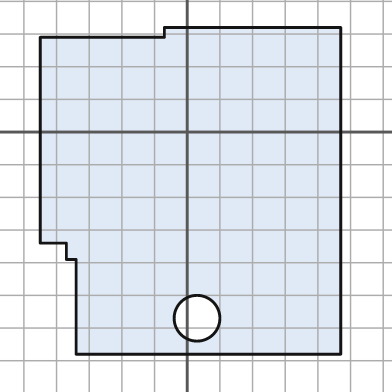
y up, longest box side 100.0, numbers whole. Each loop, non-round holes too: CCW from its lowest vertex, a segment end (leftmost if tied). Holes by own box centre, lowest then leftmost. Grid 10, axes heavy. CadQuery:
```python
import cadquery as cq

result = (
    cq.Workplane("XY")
    .moveTo(-34.0, -68.0)
    .lineTo(47.0, -68.0)
    .lineTo(47.0, 32.0)
    .lineTo(-7.0, 32.0)
    .lineTo(-7.0, 29.0)
    .lineTo(-45.0, 29.0)
    .lineTo(-45.0, -34.0)
    .lineTo(-37.0, -34.0)
    .lineTo(-37.0, -39.0)
    .lineTo(-34.0, -39.0)
    .close()
    .moveTo(3.0, -57.0)
    .circle(7.0)
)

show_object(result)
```